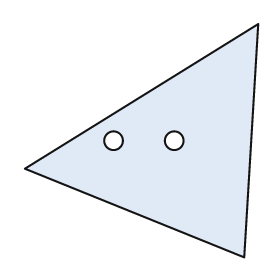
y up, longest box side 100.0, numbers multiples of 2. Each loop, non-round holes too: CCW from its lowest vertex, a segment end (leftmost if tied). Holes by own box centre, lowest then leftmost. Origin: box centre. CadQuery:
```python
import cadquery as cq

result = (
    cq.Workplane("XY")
    .moveTo(44.0, -50.0)
    .lineTo(50.0, 50.0)
    .lineTo(-50.0, -12.0)
    .close()
    .moveTo(-12.0, 0.0)
    .circle(4.0)
    .moveTo(14.0, 0.0)
    .circle(4.0)
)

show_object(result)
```